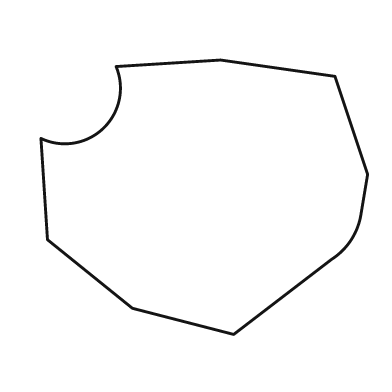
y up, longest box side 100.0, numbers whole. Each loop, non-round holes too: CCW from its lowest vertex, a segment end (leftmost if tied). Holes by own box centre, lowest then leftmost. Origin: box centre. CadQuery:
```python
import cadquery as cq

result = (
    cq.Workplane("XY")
    .moveTo(9.0, -42.0)
    .lineTo(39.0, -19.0)
    .threePointArc((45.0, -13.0), (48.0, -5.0))
    .lineTo(50.0, 7.0)
    .lineTo(40.0, 37.0)
    .lineTo(5.0, 42.0)
    .lineTo(-27.0, 40.0)
    .threePointArc((-31.0, 21.0), (-50.0, 18.0))
    .lineTo(-48.0, -13.0)
    .lineTo(-22.0, -34.0)
    .close()
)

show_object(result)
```